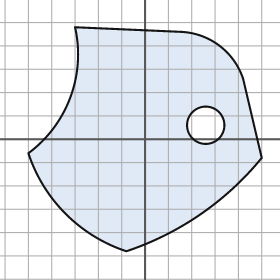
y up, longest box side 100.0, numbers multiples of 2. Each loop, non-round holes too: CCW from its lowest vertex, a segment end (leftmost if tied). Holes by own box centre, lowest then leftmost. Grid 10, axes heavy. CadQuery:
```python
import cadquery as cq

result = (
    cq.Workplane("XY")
    .moveTo(-8.0, -48.0)
    .threePointArc((24.0, -32.0), (50.0, -8.0))
    .lineTo(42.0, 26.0)
    .threePointArc((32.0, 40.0), (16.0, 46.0))
    .lineTo(-30.0, 48.0)
    .threePointArc((-32.0, 18.0), (-50.0, -6.0))
    .threePointArc((-34.0, -32.0), (-8.0, -48.0))
    .close()
    .moveTo(26.0, 6.0)
    .circle(8.0)
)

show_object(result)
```